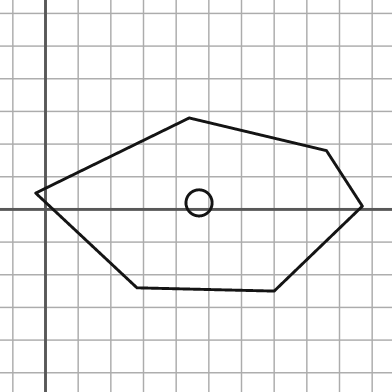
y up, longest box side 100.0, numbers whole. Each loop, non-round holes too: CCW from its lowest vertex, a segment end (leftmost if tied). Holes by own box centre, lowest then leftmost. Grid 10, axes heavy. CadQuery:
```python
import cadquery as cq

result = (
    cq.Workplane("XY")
    .moveTo(70.0, -25.0)
    .lineTo(97.0, 1.0)
    .lineTo(86.0, 18.0)
    .lineTo(44.0, 28.0)
    .lineTo(-3.0, 5.0)
    .lineTo(28.0, -24.0)
    .close()
    .moveTo(47.0, 2.0)
    .circle(4.0)
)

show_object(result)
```